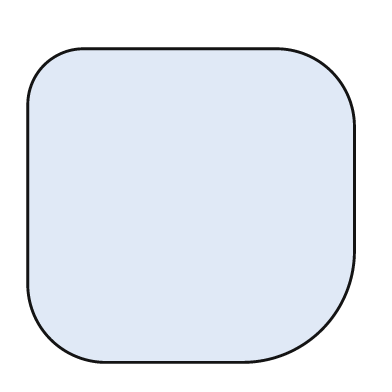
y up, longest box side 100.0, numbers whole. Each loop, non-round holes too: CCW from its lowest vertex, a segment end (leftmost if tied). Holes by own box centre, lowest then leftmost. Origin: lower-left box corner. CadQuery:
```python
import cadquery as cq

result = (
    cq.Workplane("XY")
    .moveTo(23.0, 0.0)
    .lineTo(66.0, 0.0)
    .threePointArc((90.0, 10.0), (100.0, 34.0))
    .lineTo(100.0, 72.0)
    .threePointArc((93.0, 89.0), (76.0, 96.0))
    .lineTo(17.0, 96.0)
    .threePointArc((5.0, 91.0), (0.0, 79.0))
    .lineTo(0.0, 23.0)
    .threePointArc((7.0, 7.0), (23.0, 0.0))
    .close()
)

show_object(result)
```